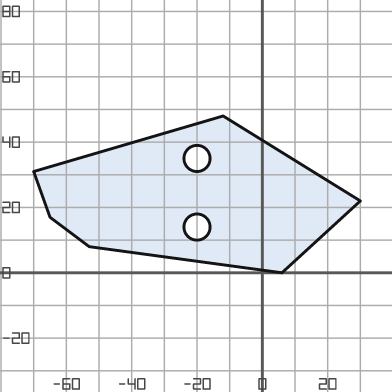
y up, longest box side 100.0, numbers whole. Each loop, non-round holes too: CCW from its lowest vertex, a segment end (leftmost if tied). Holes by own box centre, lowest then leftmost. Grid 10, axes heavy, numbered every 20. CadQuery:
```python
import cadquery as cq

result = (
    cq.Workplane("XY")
    .moveTo(6.0, 0.0)
    .lineTo(30.0, 22.0)
    .lineTo(-12.0, 48.0)
    .lineTo(-70.0, 31.0)
    .lineTo(-65.0, 17.0)
    .lineTo(-53.0, 8.0)
    .close()
    .moveTo(-20.0, 14.0)
    .circle(4.0)
    .moveTo(-20.0, 35.0)
    .circle(4.0)
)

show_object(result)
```